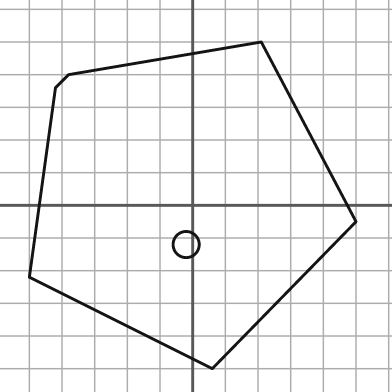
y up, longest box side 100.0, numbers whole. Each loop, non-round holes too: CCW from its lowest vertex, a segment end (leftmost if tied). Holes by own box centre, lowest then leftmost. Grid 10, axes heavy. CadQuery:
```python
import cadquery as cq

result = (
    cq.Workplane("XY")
    .moveTo(6.0, -50.0)
    .lineTo(50.0, -5.0)
    .lineTo(21.0, 50.0)
    .lineTo(-38.0, 40.0)
    .lineTo(-42.0, 36.0)
    .lineTo(-50.0, -22.0)
    .close()
    .moveTo(-2.0, -12.0)
    .circle(4.0)
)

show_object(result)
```